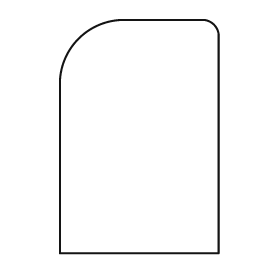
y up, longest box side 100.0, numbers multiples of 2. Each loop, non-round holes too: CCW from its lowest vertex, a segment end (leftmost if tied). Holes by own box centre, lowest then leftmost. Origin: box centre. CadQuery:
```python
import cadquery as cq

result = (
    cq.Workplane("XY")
    .moveTo(-34.0, -50.0)
    .lineTo(34.0, -50.0)
    .lineTo(34.0, 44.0)
    .threePointArc((32.0, 48.0), (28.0, 50.0))
    .lineTo(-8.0, 50.0)
    .threePointArc((-26.0, 42.0), (-34.0, 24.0))
    .close()
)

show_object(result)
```